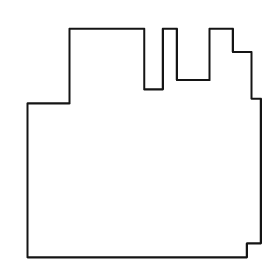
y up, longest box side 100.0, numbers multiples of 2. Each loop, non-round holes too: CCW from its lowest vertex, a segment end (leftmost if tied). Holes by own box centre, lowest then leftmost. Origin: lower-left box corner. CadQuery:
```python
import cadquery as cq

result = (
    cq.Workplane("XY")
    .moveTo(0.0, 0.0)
    .lineTo(94.0, 0.0)
    .lineTo(94.0, 6.0)
    .lineTo(100.0, 6.0)
    .lineTo(100.0, 68.0)
    .lineTo(96.0, 68.0)
    .lineTo(96.0, 88.0)
    .lineTo(88.0, 88.0)
    .lineTo(88.0, 98.0)
    .lineTo(78.0, 98.0)
    .lineTo(78.0, 76.0)
    .lineTo(64.0, 76.0)
    .lineTo(64.0, 98.0)
    .lineTo(58.0, 98.0)
    .lineTo(58.0, 72.0)
    .lineTo(50.0, 72.0)
    .lineTo(50.0, 98.0)
    .lineTo(18.0, 98.0)
    .lineTo(18.0, 66.0)
    .lineTo(0.0, 66.0)
    .close()
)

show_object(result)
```